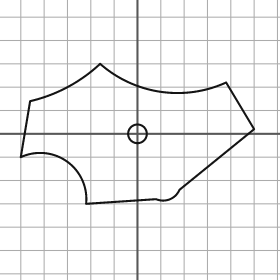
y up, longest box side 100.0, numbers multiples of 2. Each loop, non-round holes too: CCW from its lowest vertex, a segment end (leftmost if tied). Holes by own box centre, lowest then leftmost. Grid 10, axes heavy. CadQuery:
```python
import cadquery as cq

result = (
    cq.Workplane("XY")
    .moveTo(-22.0, -30.0)
    .lineTo(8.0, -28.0)
    .threePointArc((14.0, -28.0), (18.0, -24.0))
    .lineTo(50.0, 2.0)
    .lineTo(38.0, 22.0)
    .threePointArc((10.0, 18.0), (-16.0, 30.0))
    .threePointArc((-30.0, 20.0), (-46.0, 14.0))
    .lineTo(-50.0, -10.0)
    .threePointArc((-30.0, -12.0), (-22.0, -30.0))
    .close()
    .moveTo(0.0, 0.0)
    .circle(4.0)
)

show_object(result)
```